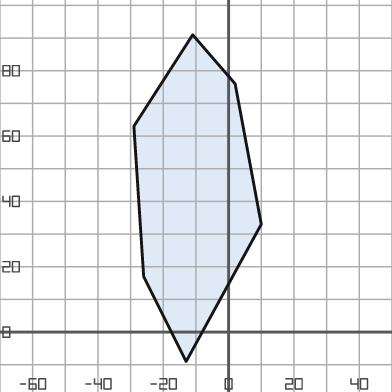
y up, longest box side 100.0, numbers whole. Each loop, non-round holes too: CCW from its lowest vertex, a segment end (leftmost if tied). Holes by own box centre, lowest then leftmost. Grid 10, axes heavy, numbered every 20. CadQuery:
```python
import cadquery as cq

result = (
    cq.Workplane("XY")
    .moveTo(-13.0, -9.0)
    .lineTo(10.0, 33.0)
    .lineTo(2.0, 76.0)
    .lineTo(-11.0, 91.0)
    .lineTo(-29.0, 63.0)
    .lineTo(-26.0, 17.0)
    .close()
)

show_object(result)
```